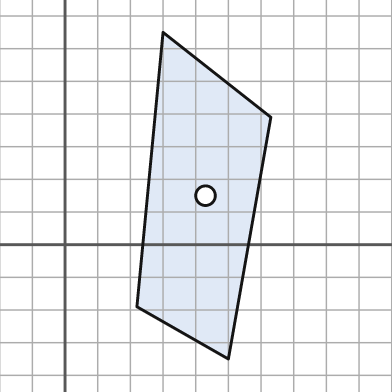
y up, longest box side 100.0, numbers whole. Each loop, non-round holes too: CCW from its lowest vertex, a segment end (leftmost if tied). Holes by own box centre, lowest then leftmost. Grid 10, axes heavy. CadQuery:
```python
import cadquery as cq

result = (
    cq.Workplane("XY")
    .moveTo(50.0, -35.0)
    .lineTo(63.0, 39.0)
    .lineTo(30.0, 65.0)
    .lineTo(22.0, -19.0)
    .close()
    .moveTo(43.0, 15.0)
    .circle(3.0)
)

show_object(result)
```